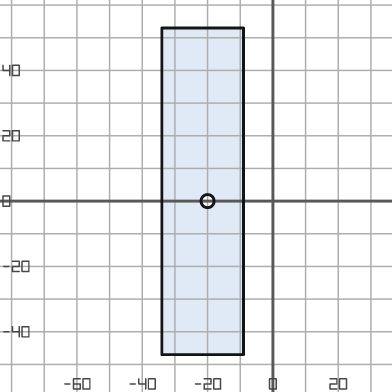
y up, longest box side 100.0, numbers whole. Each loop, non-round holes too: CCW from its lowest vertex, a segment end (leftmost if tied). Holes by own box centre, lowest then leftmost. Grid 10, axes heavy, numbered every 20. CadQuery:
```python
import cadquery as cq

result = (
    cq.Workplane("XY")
    .moveTo(-34.0, -47.0)
    .lineTo(-9.0, -47.0)
    .lineTo(-9.0, 53.0)
    .lineTo(-34.0, 53.0)
    .close()
    .moveTo(-20.0, 0.0)
    .circle(2.0)
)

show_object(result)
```